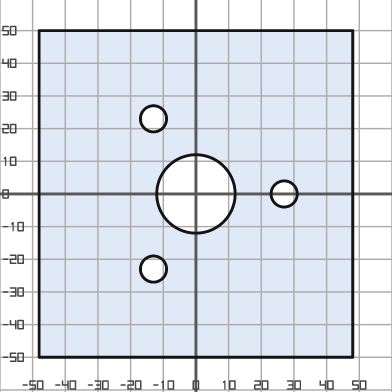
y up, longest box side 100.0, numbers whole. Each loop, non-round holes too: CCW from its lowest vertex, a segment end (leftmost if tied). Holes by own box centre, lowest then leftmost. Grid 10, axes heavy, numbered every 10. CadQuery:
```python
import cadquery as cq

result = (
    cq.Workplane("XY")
    .moveTo(-48.0, -50.0)
    .lineTo(48.0, -50.0)
    .lineTo(48.0, 50.0)
    .lineTo(-48.0, 50.0)
    .close()
    .moveTo(-13.0, -23.0)
    .circle(4.0)
    .moveTo(0.0, 0.0)
    .circle(12.0)
    .moveTo(27.0, 0.0)
    .circle(4.0)
    .moveTo(-13.0, 23.0)
    .circle(4.0)
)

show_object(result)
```